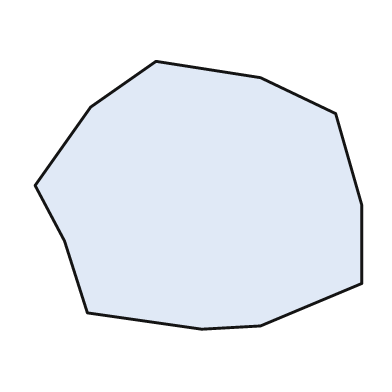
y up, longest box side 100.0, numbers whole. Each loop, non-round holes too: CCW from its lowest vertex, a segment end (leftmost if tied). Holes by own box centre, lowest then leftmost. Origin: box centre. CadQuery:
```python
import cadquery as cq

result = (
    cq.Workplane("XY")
    .moveTo(1.0, -41.0)
    .lineTo(19.0, -40.0)
    .lineTo(50.0, -27.0)
    .lineTo(50.0, -3.0)
    .lineTo(42.0, 25.0)
    .lineTo(19.0, 36.0)
    .lineTo(-13.0, 41.0)
    .lineTo(-33.0, 27.0)
    .lineTo(-50.0, 3.0)
    .lineTo(-41.0, -14.0)
    .lineTo(-34.0, -36.0)
    .close()
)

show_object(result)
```